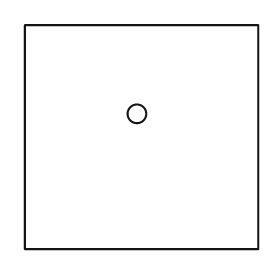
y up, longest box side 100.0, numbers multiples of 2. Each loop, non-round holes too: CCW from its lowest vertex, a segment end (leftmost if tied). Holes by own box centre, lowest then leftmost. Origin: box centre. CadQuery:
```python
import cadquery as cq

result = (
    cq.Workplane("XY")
    .moveTo(-50.0, -48.0)
    .lineTo(50.0, -48.0)
    .lineTo(50.0, 48.0)
    .lineTo(-50.0, 48.0)
    .close()
    .moveTo(-2.0, 10.0)
    .circle(4.0)
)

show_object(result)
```